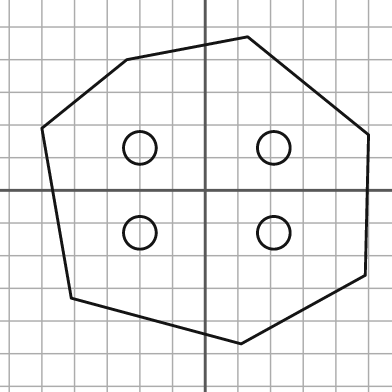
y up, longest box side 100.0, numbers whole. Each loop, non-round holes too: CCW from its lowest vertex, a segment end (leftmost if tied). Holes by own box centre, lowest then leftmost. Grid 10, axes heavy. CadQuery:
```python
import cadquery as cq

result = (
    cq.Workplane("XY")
    .moveTo(11.0, -47.0)
    .lineTo(49.0, -26.0)
    .lineTo(50.0, 17.0)
    .lineTo(13.0, 47.0)
    .lineTo(-24.0, 40.0)
    .lineTo(-50.0, 19.0)
    .lineTo(-41.0, -33.0)
    .close()
    .moveTo(-20.0, -13.0)
    .circle(5.0)
    .moveTo(21.0, -13.0)
    .circle(5.0)
    .moveTo(-20.0, 13.0)
    .circle(5.0)
    .moveTo(21.0, 13.0)
    .circle(5.0)
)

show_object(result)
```